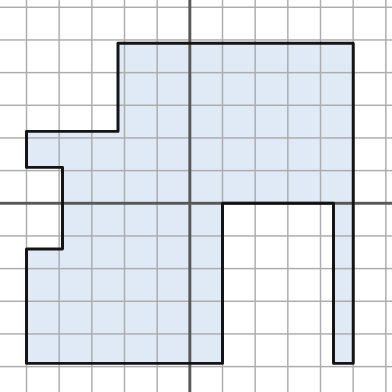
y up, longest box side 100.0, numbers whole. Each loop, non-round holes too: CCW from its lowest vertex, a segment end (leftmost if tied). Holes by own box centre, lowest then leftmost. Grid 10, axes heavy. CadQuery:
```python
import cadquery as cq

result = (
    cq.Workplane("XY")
    .moveTo(-50.0, -49.0)
    .lineTo(10.0, -49.0)
    .lineTo(10.0, 0.0)
    .lineTo(44.0, 0.0)
    .lineTo(44.0, -49.0)
    .lineTo(50.0, -49.0)
    .lineTo(50.0, 49.0)
    .lineTo(-22.0, 49.0)
    .lineTo(-22.0, 22.0)
    .lineTo(-50.0, 22.0)
    .lineTo(-50.0, 11.0)
    .lineTo(-39.0, 11.0)
    .lineTo(-39.0, -14.0)
    .lineTo(-50.0, -14.0)
    .close()
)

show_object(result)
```